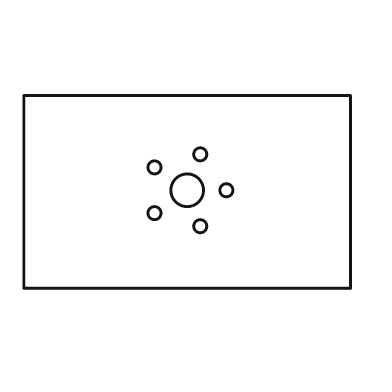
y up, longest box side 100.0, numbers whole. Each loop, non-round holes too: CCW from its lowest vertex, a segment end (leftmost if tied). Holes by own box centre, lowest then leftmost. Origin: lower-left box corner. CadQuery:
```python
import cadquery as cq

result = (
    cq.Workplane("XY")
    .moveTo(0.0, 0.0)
    .lineTo(100.0, 0.0)
    .lineTo(100.0, 59.0)
    .lineTo(0.0, 59.0)
    .close()
    .moveTo(54.0, 19.0)
    .circle(2.0)
    .moveTo(40.0, 23.0)
    .circle(2.0)
    .moveTo(50.0, 30.0)
    .circle(5.0)
    .moveTo(62.0, 30.0)
    .circle(2.0)
    .moveTo(40.0, 37.0)
    .circle(2.0)
    .moveTo(54.0, 41.0)
    .circle(2.0)
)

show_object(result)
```